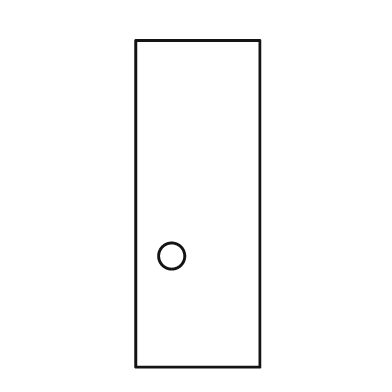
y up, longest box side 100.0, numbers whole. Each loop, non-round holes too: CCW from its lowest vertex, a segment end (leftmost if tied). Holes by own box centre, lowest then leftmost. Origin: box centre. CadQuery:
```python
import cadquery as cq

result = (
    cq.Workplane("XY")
    .moveTo(-19.0, -50.0)
    .lineTo(19.0, -50.0)
    .lineTo(19.0, 50.0)
    .lineTo(-19.0, 50.0)
    .close()
    .moveTo(-8.0, -16.0)
    .circle(4.0)
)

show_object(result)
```